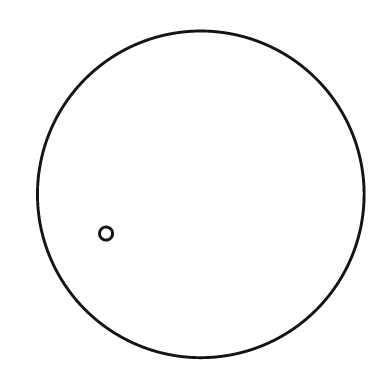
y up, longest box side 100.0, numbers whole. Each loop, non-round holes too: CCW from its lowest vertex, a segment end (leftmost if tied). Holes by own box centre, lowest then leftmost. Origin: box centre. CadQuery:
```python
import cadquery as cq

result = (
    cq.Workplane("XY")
    .moveTo(0.0, 0.0)
    .circle(50.0)
    .moveTo(-29.0, -12.0)
    .circle(2.0)
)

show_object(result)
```